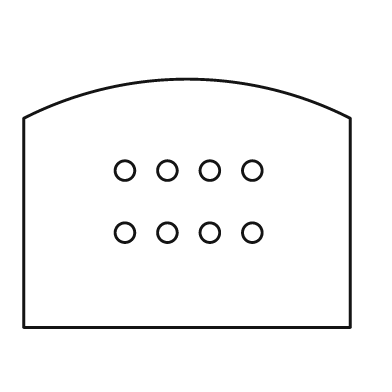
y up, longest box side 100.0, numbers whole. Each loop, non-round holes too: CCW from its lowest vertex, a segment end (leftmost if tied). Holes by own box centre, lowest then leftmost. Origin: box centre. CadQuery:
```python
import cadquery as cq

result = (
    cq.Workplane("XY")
    .moveTo(-50.0, -38.0)
    .lineTo(50.0, -38.0)
    .lineTo(50.0, 26.0)
    .threePointArc((0.0, 38.0), (-50.0, 26.0))
    .close()
    .moveTo(-19.0, -9.0)
    .circle(3.0)
    .moveTo(-6.0, -9.0)
    .circle(3.0)
    .moveTo(7.0, -9.0)
    .circle(3.0)
    .moveTo(20.0, -9.0)
    .circle(3.0)
    .moveTo(-19.0, 10.0)
    .circle(3.0)
    .moveTo(-6.0, 10.0)
    .circle(3.0)
    .moveTo(7.0, 10.0)
    .circle(3.0)
    .moveTo(20.0, 10.0)
    .circle(3.0)
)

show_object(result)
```